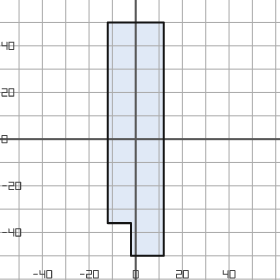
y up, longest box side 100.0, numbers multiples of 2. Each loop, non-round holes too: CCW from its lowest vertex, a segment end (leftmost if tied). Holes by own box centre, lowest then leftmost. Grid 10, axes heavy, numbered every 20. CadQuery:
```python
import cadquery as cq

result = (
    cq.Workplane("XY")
    .moveTo(-2.0, -50.0)
    .lineTo(12.0, -50.0)
    .lineTo(12.0, 50.0)
    .lineTo(-12.0, 50.0)
    .lineTo(-12.0, -36.0)
    .lineTo(-2.0, -36.0)
    .close()
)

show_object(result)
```